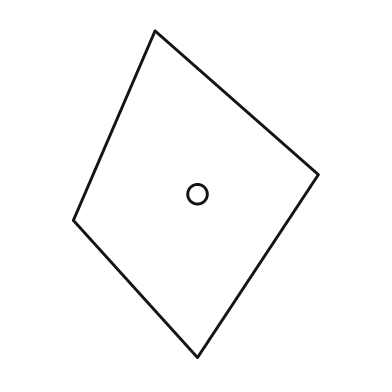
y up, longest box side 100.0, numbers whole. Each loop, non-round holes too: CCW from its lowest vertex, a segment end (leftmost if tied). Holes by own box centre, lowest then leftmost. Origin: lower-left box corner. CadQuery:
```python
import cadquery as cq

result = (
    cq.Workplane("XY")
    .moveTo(38.0, 0.0)
    .lineTo(75.0, 56.0)
    .lineTo(25.0, 100.0)
    .lineTo(0.0, 42.0)
    .close()
    .moveTo(38.0, 50.0)
    .circle(3.0)
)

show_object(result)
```